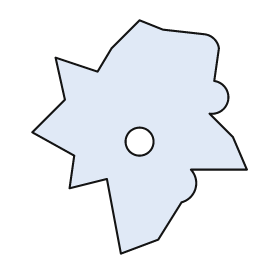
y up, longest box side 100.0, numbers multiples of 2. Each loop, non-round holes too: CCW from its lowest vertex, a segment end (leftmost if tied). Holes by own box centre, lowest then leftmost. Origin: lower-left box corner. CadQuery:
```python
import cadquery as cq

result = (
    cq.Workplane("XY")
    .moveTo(38.0, 0.0)
    .lineTo(54.0, 6.0)
    .lineTo(64.0, 22.0)
    .threePointArc((70.0, 28.0), (68.0, 36.0))
    .lineTo(92.0, 36.0)
    .lineTo(86.0, 50.0)
    .lineTo(76.0, 60.0)
    .threePointArc((84.0, 66.0), (78.0, 74.0))
    .lineTo(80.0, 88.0)
    .threePointArc((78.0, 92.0), (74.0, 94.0))
    .lineTo(56.0, 96.0)
    .lineTo(46.0, 100.0)
    .lineTo(34.0, 88.0)
    .lineTo(28.0, 78.0)
    .lineTo(10.0, 84.0)
    .lineTo(14.0, 66.0)
    .lineTo(0.0, 52.0)
    .lineTo(18.0, 42.0)
    .lineTo(16.0, 28.0)
    .lineTo(32.0, 32.0)
    .close()
    .moveTo(46.0, 48.0)
    .circle(6.0)
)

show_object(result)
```